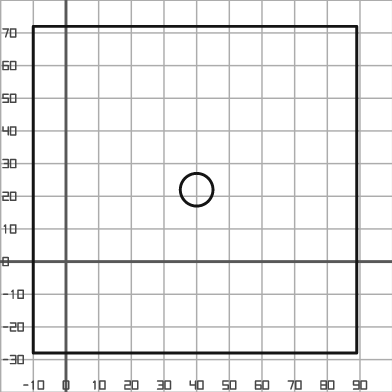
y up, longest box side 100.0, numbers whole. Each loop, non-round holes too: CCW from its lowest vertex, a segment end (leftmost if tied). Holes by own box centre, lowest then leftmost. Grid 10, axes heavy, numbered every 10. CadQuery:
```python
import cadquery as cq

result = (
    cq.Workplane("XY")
    .moveTo(-10.0, -28.0)
    .lineTo(89.0, -28.0)
    .lineTo(89.0, 72.0)
    .lineTo(-10.0, 72.0)
    .close()
    .moveTo(40.0, 22.0)
    .circle(5.0)
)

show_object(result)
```